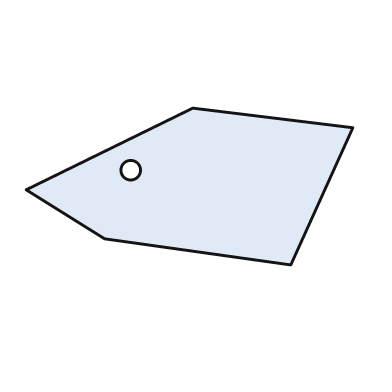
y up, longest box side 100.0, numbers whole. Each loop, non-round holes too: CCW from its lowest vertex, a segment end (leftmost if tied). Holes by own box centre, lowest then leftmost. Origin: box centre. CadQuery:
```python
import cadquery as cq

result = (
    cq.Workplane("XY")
    .moveTo(31.0, -24.0)
    .lineTo(50.0, 18.0)
    .lineTo(1.0, 24.0)
    .lineTo(-50.0, -1.0)
    .lineTo(-26.0, -16.0)
    .close()
    .moveTo(-18.0, 5.0)
    .circle(3.0)
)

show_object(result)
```